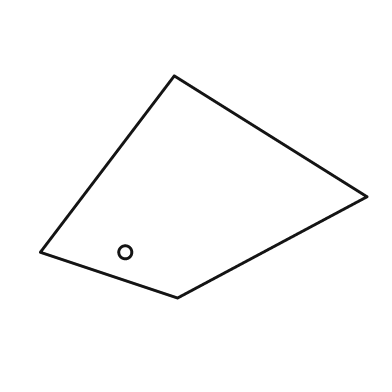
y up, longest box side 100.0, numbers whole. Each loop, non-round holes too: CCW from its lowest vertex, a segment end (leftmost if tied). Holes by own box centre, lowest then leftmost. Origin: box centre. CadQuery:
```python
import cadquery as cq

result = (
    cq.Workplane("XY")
    .moveTo(-8.0, -34.0)
    .lineTo(50.0, -3.0)
    .lineTo(-9.0, 34.0)
    .lineTo(-50.0, -20.0)
    .close()
    .moveTo(-24.0, -20.0)
    .circle(2.0)
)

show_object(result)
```